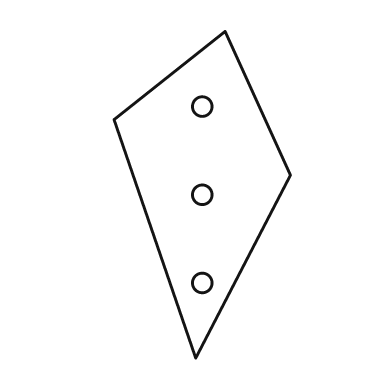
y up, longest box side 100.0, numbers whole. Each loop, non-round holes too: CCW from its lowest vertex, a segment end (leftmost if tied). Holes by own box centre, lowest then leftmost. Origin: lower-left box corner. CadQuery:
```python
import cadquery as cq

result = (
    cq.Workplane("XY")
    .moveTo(25.0, 0.0)
    .lineTo(54.0, 56.0)
    .lineTo(34.0, 100.0)
    .lineTo(0.0, 73.0)
    .close()
    .moveTo(27.0, 23.0)
    .circle(3.0)
    .moveTo(27.0, 50.0)
    .circle(3.0)
    .moveTo(27.0, 77.0)
    .circle(3.0)
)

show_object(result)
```